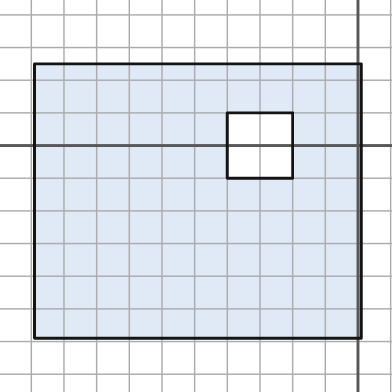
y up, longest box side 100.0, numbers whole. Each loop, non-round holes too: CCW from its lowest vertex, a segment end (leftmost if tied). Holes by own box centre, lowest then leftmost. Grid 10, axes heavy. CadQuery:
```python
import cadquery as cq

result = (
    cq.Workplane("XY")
    .moveTo(-99.0, -59.0)
    .lineTo(1.0, -59.0)
    .lineTo(1.0, 25.0)
    .lineTo(-99.0, 25.0)
    .close()
    .moveTo(-40.0, -10.0)
    .lineTo(-20.0, -10.0)
    .lineTo(-20.0, 10.0)
    .lineTo(-40.0, 10.0)
    .close()
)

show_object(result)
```